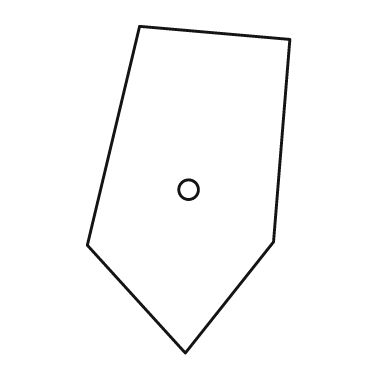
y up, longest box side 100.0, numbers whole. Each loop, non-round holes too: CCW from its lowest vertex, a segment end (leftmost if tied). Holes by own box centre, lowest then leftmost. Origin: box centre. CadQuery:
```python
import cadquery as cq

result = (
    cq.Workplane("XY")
    .moveTo(-1.0, -50.0)
    .lineTo(26.0, -16.0)
    .lineTo(31.0, 46.0)
    .lineTo(-15.0, 50.0)
    .lineTo(-31.0, -17.0)
    .close()
    .moveTo(0.0, 0.0)
    .circle(3.0)
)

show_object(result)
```